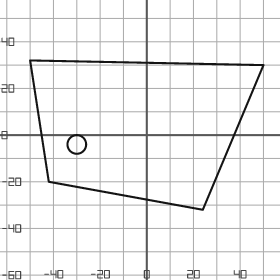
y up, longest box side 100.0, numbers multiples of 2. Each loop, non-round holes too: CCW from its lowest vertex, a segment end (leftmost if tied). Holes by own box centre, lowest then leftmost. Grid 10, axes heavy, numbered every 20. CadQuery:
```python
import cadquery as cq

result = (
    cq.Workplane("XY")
    .moveTo(24.0, -32.0)
    .lineTo(50.0, 30.0)
    .lineTo(-50.0, 32.0)
    .lineTo(-42.0, -20.0)
    .close()
    .moveTo(-30.0, -4.0)
    .circle(4.0)
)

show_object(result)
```